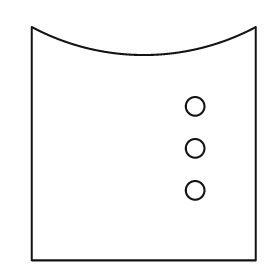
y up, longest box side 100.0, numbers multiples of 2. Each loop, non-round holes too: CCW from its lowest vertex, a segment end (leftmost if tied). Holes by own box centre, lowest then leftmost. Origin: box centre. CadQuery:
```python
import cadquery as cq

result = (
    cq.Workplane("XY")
    .moveTo(-48.0, -50.0)
    .lineTo(48.0, -50.0)
    .lineTo(48.0, 50.0)
    .threePointArc((0.0, 38.0), (-48.0, 50.0))
    .close()
    .moveTo(22.0, -20.0)
    .circle(4.0)
    .moveTo(22.0, -2.0)
    .circle(4.0)
    .moveTo(22.0, 16.0)
    .circle(4.0)
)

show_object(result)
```